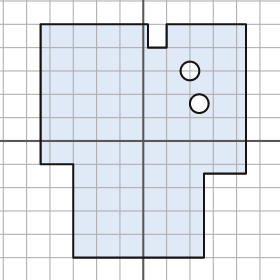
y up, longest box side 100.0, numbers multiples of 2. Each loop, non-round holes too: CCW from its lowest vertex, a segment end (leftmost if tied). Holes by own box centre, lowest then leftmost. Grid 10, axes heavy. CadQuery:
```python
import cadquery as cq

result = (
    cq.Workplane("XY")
    .moveTo(-30.0, -50.0)
    .lineTo(26.0, -50.0)
    .lineTo(26.0, -14.0)
    .lineTo(44.0, -14.0)
    .lineTo(44.0, 50.0)
    .lineTo(10.0, 50.0)
    .lineTo(10.0, 40.0)
    .lineTo(2.0, 40.0)
    .lineTo(2.0, 50.0)
    .lineTo(-44.0, 50.0)
    .lineTo(-44.0, -10.0)
    .lineTo(-30.0, -10.0)
    .close()
    .moveTo(24.0, 16.0)
    .circle(4.0)
    .moveTo(20.0, 30.0)
    .circle(4.0)
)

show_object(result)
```